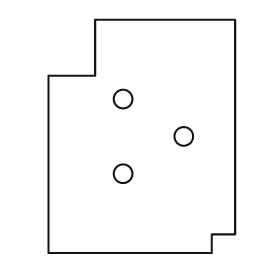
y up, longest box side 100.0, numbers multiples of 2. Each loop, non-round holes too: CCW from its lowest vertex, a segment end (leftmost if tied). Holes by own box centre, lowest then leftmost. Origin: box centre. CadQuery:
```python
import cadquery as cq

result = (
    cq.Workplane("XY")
    .moveTo(-40.0, -50.0)
    .lineTo(30.0, -50.0)
    .lineTo(30.0, -42.0)
    .lineTo(40.0, -42.0)
    .lineTo(40.0, 50.0)
    .lineTo(-20.0, 50.0)
    .lineTo(-20.0, 26.0)
    .lineTo(-40.0, 26.0)
    .close()
    .moveTo(-8.0, -16.0)
    .circle(4.0)
    .moveTo(18.0, 0.0)
    .circle(4.0)
    .moveTo(-8.0, 16.0)
    .circle(4.0)
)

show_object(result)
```